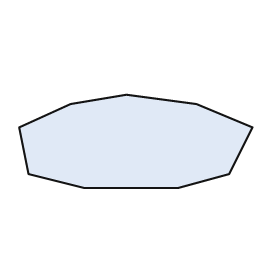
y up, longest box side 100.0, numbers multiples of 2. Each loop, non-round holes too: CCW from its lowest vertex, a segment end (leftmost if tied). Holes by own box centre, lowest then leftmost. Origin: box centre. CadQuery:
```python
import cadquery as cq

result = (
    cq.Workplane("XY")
    .moveTo(-22.0, -20.0)
    .lineTo(18.0, -20.0)
    .lineTo(40.0, -14.0)
    .lineTo(50.0, 6.0)
    .lineTo(26.0, 16.0)
    .lineTo(-4.0, 20.0)
    .lineTo(-28.0, 16.0)
    .lineTo(-50.0, 6.0)
    .lineTo(-46.0, -14.0)
    .close()
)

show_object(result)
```